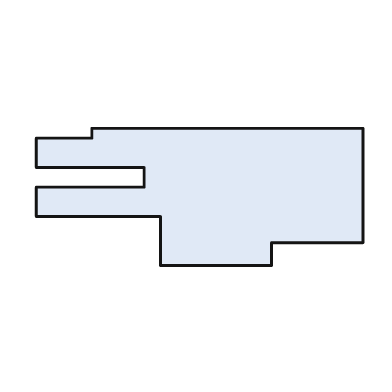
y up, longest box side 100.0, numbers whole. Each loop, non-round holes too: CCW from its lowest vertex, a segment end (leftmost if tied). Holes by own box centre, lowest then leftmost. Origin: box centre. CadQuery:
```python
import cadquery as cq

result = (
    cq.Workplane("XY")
    .moveTo(-12.0, -21.0)
    .lineTo(22.0, -21.0)
    .lineTo(22.0, -14.0)
    .lineTo(50.0, -14.0)
    .lineTo(50.0, 21.0)
    .lineTo(-33.0, 21.0)
    .lineTo(-33.0, 18.0)
    .lineTo(-50.0, 18.0)
    .lineTo(-50.0, 9.0)
    .lineTo(-17.0, 9.0)
    .lineTo(-17.0, 3.0)
    .lineTo(-50.0, 3.0)
    .lineTo(-50.0, -6.0)
    .lineTo(-12.0, -6.0)
    .close()
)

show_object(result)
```